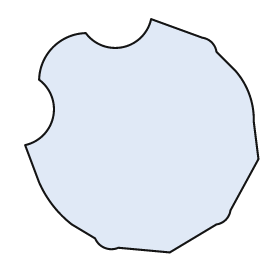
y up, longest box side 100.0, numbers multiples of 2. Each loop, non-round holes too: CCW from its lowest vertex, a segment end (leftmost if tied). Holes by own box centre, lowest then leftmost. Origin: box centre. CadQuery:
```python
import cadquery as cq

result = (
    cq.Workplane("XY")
    .moveTo(12.0, -50.0)
    .lineTo(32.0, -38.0)
    .threePointArc((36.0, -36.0), (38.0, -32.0))
    .lineTo(50.0, -10.0)
    .lineTo(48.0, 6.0)
    .threePointArc((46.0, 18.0), (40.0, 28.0))
    .lineTo(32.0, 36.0)
    .threePointArc((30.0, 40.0), (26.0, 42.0))
    .lineTo(4.0, 50.0)
    .threePointArc((-8.0, 38.0), (-24.0, 44.0))
    .threePointArc((-38.0, 38.0), (-44.0, 24.0))
    .threePointArc((-38.0, 8.0), (-50.0, -4.0))
    .lineTo(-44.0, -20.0)
    .threePointArc((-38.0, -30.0), (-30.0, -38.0))
    .lineTo(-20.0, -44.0)
    .threePointArc((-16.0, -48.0), (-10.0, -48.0))
    .close()
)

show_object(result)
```